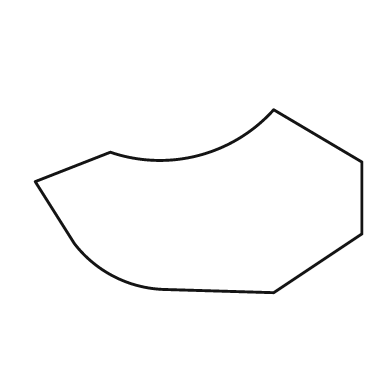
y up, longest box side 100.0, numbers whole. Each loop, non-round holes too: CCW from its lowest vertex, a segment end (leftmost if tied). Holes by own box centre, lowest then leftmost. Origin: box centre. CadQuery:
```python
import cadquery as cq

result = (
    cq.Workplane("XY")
    .moveTo(23.0, -28.0)
    .lineTo(50.0, -10.0)
    .lineTo(50.0, 12.0)
    .lineTo(23.0, 28.0)
    .threePointArc((0.0, 14.0), (-27.0, 15.0))
    .lineTo(-50.0, 6.0)
    .lineTo(-38.0, -13.0)
    .threePointArc((-26.0, -23.0), (-11.0, -27.0))
    .close()
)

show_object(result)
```